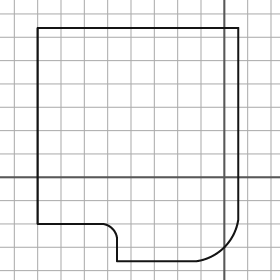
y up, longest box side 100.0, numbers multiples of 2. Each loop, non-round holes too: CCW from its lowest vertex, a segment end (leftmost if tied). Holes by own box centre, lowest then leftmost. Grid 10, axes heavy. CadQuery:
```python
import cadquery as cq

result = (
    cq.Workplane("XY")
    .moveTo(-46.0, -36.0)
    .lineTo(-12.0, -36.0)
    .threePointArc((0.0, -30.0), (6.0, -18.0))
    .lineTo(6.0, 64.0)
    .lineTo(-80.0, 64.0)
    .lineTo(-80.0, -20.0)
    .lineTo(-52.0, -20.0)
    .threePointArc((-48.0, -22.0), (-46.0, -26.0))
    .close()
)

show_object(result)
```